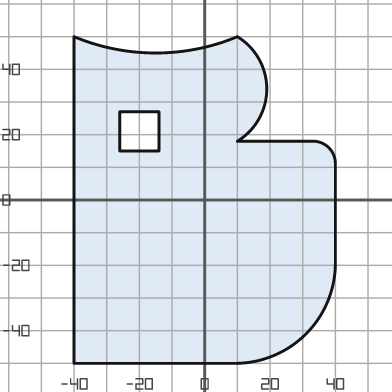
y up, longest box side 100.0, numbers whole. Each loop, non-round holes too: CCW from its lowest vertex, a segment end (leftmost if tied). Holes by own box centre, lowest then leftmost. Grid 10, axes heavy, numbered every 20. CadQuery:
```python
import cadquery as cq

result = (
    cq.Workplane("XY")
    .moveTo(-40.0, -50.0)
    .lineTo(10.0, -50.0)
    .threePointArc((31.0, -41.0), (40.0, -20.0))
    .lineTo(40.0, 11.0)
    .threePointArc((38.0, 16.0), (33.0, 18.0))
    .lineTo(10.0, 18.0)
    .threePointArc((19.0, 34.0), (10.0, 50.0))
    .threePointArc((-15.0, 45.0), (-40.0, 50.0))
    .close()
    .moveTo(-26.0, 15.0)
    .lineTo(-14.0, 15.0)
    .lineTo(-14.0, 27.0)
    .lineTo(-26.0, 27.0)
    .close()
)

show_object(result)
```